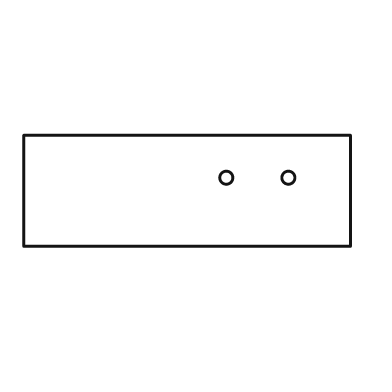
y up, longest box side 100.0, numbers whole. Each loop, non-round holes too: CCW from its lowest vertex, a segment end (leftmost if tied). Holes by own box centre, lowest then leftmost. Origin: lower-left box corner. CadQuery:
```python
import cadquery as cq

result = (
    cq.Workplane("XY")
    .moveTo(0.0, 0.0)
    .lineTo(100.0, 0.0)
    .lineTo(100.0, 34.0)
    .lineTo(0.0, 34.0)
    .close()
    .moveTo(62.0, 21.0)
    .circle(2.0)
    .moveTo(81.0, 21.0)
    .circle(2.0)
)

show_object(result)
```